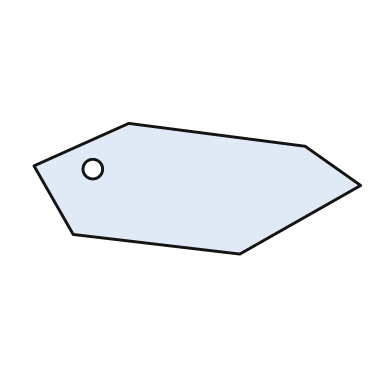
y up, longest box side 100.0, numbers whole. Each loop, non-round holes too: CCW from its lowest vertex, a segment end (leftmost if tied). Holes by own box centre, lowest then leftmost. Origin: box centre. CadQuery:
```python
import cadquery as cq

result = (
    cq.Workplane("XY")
    .moveTo(13.0, -20.0)
    .lineTo(50.0, 1.0)
    .lineTo(33.0, 13.0)
    .lineTo(-21.0, 20.0)
    .lineTo(-50.0, 7.0)
    .lineTo(-38.0, -14.0)
    .close()
    .moveTo(-32.0, 6.0)
    .circle(3.0)
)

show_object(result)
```